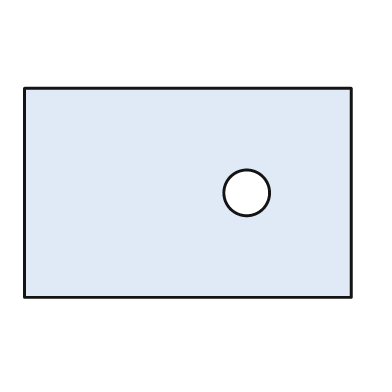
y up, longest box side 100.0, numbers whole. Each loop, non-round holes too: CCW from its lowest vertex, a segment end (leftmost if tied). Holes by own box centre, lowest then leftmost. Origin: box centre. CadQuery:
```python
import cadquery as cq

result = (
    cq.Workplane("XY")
    .moveTo(-50.0, -32.0)
    .lineTo(50.0, -32.0)
    .lineTo(50.0, 32.0)
    .lineTo(-50.0, 32.0)
    .close()
    .moveTo(18.0, 0.0)
    .circle(7.0)
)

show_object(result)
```